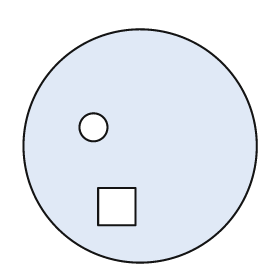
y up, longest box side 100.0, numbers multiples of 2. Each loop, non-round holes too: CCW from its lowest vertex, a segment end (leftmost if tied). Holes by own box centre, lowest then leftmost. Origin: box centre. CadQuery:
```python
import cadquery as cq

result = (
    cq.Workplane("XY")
    .moveTo(0.0, 0.0)
    .circle(50.0)
    .moveTo(-18.0, -34.0)
    .lineTo(-2.0, -34.0)
    .lineTo(-2.0, -18.0)
    .lineTo(-18.0, -18.0)
    .close()
    .moveTo(-20.0, 8.0)
    .circle(6.0)
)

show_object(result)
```